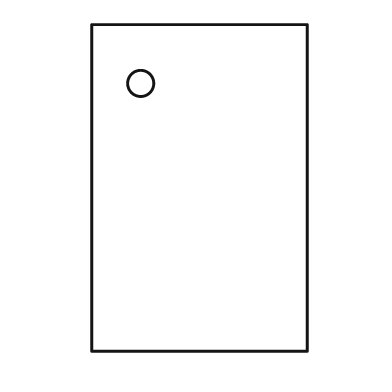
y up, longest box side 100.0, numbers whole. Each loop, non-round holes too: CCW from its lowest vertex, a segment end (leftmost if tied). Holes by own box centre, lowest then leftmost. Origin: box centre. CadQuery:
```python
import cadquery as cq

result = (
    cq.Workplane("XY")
    .moveTo(-33.0, -50.0)
    .lineTo(33.0, -50.0)
    .lineTo(33.0, 50.0)
    .lineTo(-33.0, 50.0)
    .close()
    .moveTo(-18.0, 32.0)
    .circle(4.0)
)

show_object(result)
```